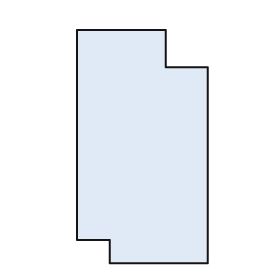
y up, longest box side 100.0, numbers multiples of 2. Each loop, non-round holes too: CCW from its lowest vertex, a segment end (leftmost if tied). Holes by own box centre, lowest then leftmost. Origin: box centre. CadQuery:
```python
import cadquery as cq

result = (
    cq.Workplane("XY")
    .moveTo(-14.0, -50.0)
    .lineTo(28.0, -50.0)
    .lineTo(28.0, 34.0)
    .lineTo(10.0, 34.0)
    .lineTo(10.0, 50.0)
    .lineTo(-28.0, 50.0)
    .lineTo(-28.0, -40.0)
    .lineTo(-14.0, -40.0)
    .close()
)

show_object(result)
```